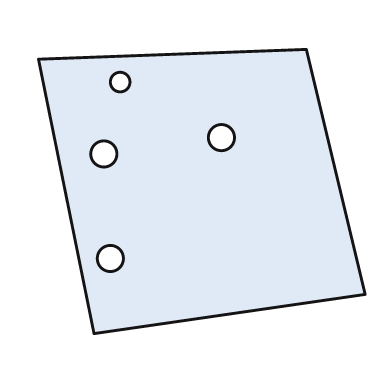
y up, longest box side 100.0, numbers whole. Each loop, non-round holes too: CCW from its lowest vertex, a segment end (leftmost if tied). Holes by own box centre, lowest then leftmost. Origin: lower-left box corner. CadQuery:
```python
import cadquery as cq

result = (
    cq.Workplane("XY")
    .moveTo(17.0, 0.0)
    .lineTo(100.0, 12.0)
    .lineTo(82.0, 87.0)
    .lineTo(0.0, 84.0)
    .close()
    .moveTo(22.0, 23.0)
    .circle(4.0)
    .moveTo(20.0, 55.0)
    .circle(4.0)
    .moveTo(56.0, 60.0)
    .circle(4.0)
    .moveTo(25.0, 77.0)
    .circle(3.0)
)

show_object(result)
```